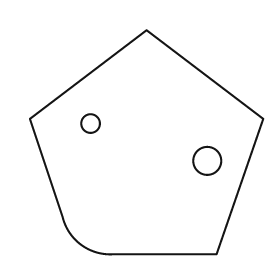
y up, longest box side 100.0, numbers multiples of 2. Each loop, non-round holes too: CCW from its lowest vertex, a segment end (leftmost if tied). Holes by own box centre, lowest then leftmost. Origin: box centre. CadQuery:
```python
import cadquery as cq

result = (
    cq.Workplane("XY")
    .moveTo(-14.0, -48.0)
    .lineTo(30.0, -48.0)
    .lineTo(50.0, 10.0)
    .lineTo(0.0, 48.0)
    .lineTo(-50.0, 10.0)
    .lineTo(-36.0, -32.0)
    .threePointArc((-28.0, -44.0), (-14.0, -48.0))
    .close()
    .moveTo(26.0, -8.0)
    .circle(6.0)
    .moveTo(-24.0, 8.0)
    .circle(4.0)
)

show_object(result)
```